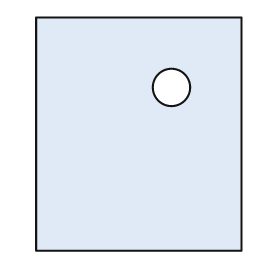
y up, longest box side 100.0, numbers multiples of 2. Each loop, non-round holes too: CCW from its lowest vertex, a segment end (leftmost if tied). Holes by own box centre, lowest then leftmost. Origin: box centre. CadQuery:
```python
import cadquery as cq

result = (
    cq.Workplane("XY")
    .moveTo(-44.0, -50.0)
    .lineTo(44.0, -50.0)
    .lineTo(44.0, 50.0)
    .lineTo(-44.0, 50.0)
    .close()
    .moveTo(14.0, 20.0)
    .circle(8.0)
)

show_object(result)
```